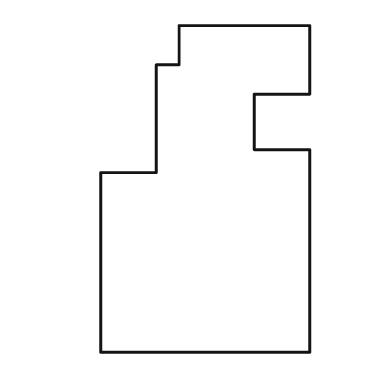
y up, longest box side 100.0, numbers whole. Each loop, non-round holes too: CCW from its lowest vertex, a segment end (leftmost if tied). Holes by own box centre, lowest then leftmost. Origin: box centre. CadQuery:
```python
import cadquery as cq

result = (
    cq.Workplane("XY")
    .moveTo(-32.0, -50.0)
    .lineTo(32.0, -50.0)
    .lineTo(32.0, 12.0)
    .lineTo(15.0, 12.0)
    .lineTo(15.0, 29.0)
    .lineTo(32.0, 29.0)
    .lineTo(32.0, 50.0)
    .lineTo(-8.0, 50.0)
    .lineTo(-8.0, 38.0)
    .lineTo(-15.0, 38.0)
    .lineTo(-15.0, 5.0)
    .lineTo(-32.0, 5.0)
    .close()
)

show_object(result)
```